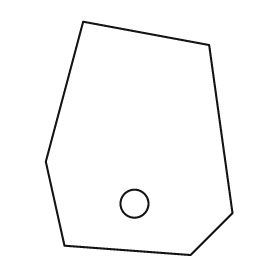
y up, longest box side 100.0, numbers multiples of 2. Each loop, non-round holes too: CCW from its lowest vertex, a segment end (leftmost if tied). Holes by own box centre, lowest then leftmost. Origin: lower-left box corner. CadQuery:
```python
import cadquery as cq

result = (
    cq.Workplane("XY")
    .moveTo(62.0, 0.0)
    .lineTo(80.0, 18.0)
    .lineTo(70.0, 90.0)
    .lineTo(16.0, 100.0)
    .lineTo(0.0, 40.0)
    .lineTo(8.0, 4.0)
    .close()
    .moveTo(38.0, 22.0)
    .circle(6.0)
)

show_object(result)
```